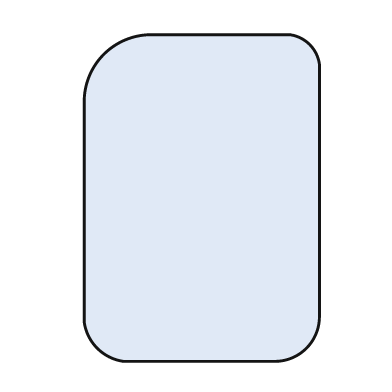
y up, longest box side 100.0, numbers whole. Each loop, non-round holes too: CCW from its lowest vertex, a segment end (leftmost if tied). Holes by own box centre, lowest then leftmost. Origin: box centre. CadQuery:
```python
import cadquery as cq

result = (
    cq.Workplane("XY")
    .moveTo(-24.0, -50.0)
    .lineTo(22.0, -50.0)
    .threePointArc((32.0, -46.0), (36.0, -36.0))
    .lineTo(36.0, 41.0)
    .threePointArc((33.0, 47.0), (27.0, 50.0))
    .lineTo(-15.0, 50.0)
    .threePointArc((-30.0, 44.0), (-36.0, 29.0))
    .lineTo(-36.0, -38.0)
    .threePointArc((-32.0, -46.0), (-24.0, -50.0))
    .close()
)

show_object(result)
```